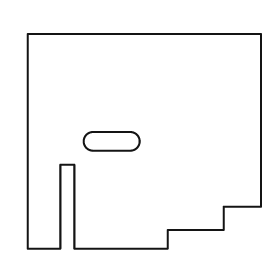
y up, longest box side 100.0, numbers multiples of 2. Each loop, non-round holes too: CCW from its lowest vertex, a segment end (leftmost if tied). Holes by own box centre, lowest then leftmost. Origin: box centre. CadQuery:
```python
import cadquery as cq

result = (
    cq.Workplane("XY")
    .moveTo(-50.0, -46.0)
    .lineTo(-36.0, -46.0)
    .lineTo(-36.0, -10.0)
    .lineTo(-30.0, -10.0)
    .lineTo(-30.0, -46.0)
    .lineTo(10.0, -46.0)
    .lineTo(10.0, -38.0)
    .lineTo(34.0, -38.0)
    .lineTo(34.0, -28.0)
    .lineTo(50.0, -28.0)
    .lineTo(50.0, 46.0)
    .lineTo(-50.0, 46.0)
    .close()
    .moveTo(-22.0, -4.0)
    .lineTo(-6.0, -4.0)
    .threePointArc((-2.0, 0.0), (-6.0, 4.0))
    .lineTo(-22.0, 4.0)
    .threePointArc((-26.0, 0.0), (-22.0, -4.0))
    .close()
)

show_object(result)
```